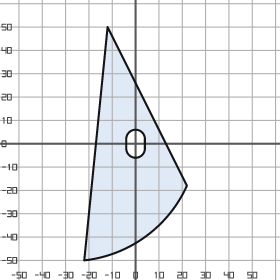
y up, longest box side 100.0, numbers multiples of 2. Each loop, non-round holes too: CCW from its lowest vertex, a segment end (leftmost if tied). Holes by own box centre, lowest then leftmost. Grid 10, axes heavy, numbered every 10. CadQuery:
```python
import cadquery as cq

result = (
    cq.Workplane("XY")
    .moveTo(-22.0, -50.0)
    .threePointArc((4.0, -40.0), (22.0, -18.0))
    .lineTo(-12.0, 50.0)
    .close()
    .moveTo(-4.0, -2.0)
    .threePointArc((0.0, -6.0), (4.0, -2.0))
    .lineTo(4.0, 2.0)
    .threePointArc((0.0, 6.0), (-4.0, 2.0))
    .close()
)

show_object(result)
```